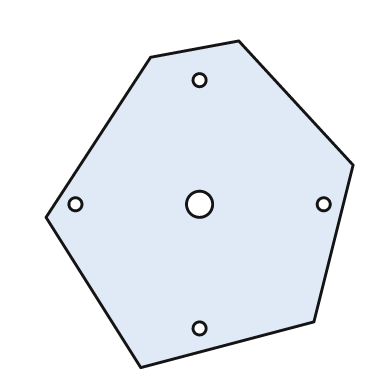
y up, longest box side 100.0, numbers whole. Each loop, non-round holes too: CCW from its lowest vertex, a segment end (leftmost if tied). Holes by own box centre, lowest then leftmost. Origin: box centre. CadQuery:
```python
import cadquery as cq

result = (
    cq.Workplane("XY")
    .moveTo(-18.0, -50.0)
    .lineTo(35.0, -36.0)
    .lineTo(47.0, 12.0)
    .lineTo(12.0, 50.0)
    .lineTo(-15.0, 45.0)
    .lineTo(-47.0, -4.0)
    .close()
    .moveTo(0.0, -38.0)
    .circle(2.0)
    .moveTo(-38.0, 0.0)
    .circle(2.0)
    .moveTo(0.0, 0.0)
    .circle(4.0)
    .moveTo(38.0, 0.0)
    .circle(2.0)
    .moveTo(0.0, 38.0)
    .circle(2.0)
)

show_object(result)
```